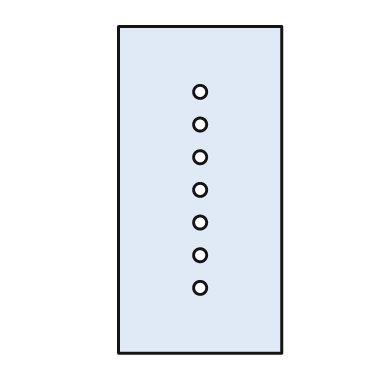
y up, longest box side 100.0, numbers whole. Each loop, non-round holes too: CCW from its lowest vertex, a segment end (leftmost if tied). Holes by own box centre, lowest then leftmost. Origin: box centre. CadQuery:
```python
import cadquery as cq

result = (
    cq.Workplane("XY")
    .moveTo(-25.0, -50.0)
    .lineTo(25.0, -50.0)
    .lineTo(25.0, 50.0)
    .lineTo(-25.0, 50.0)
    .close()
    .moveTo(0.0, -30.0)
    .circle(2.0)
    .moveTo(0.0, -20.0)
    .circle(2.0)
    .moveTo(0.0, -10.0)
    .circle(2.0)
    .moveTo(0.0, 0.0)
    .circle(2.0)
    .moveTo(0.0, 10.0)
    .circle(2.0)
    .moveTo(0.0, 20.0)
    .circle(2.0)
    .moveTo(0.0, 30.0)
    .circle(2.0)
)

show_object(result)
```